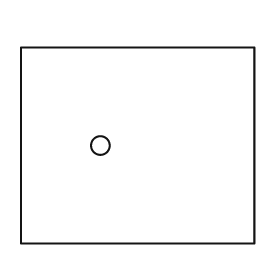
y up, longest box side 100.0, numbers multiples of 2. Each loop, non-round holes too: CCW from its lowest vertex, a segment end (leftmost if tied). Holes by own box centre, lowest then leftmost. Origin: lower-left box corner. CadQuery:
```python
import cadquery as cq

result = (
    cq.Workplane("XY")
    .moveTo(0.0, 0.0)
    .lineTo(100.0, 0.0)
    .lineTo(100.0, 84.0)
    .lineTo(0.0, 84.0)
    .close()
    .moveTo(34.0, 42.0)
    .circle(4.0)
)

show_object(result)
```